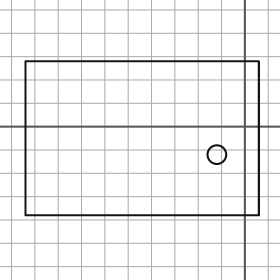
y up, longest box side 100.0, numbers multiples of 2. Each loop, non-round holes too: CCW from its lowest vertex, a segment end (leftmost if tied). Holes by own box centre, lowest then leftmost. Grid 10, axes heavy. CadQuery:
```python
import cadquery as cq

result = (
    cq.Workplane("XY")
    .moveTo(-94.0, -38.0)
    .lineTo(6.0, -38.0)
    .lineTo(6.0, 28.0)
    .lineTo(-94.0, 28.0)
    .close()
    .moveTo(-12.0, -12.0)
    .circle(4.0)
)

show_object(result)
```